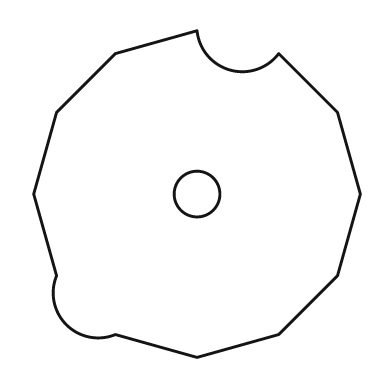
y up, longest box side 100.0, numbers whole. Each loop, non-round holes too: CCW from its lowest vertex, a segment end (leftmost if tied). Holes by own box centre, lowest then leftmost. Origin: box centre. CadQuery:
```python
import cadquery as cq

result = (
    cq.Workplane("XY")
    .moveTo(0.0, -50.0)
    .lineTo(25.0, -43.0)
    .lineTo(43.0, -25.0)
    .lineTo(50.0, 0.0)
    .lineTo(43.0, 25.0)
    .lineTo(25.0, 43.0)
    .threePointArc((10.0, 38.0), (0.0, 50.0))
    .lineTo(-25.0, 43.0)
    .lineTo(-43.0, 25.0)
    .lineTo(-50.0, 0.0)
    .lineTo(-43.0, -25.0)
    .threePointArc((-40.0, -40.0), (-25.0, -43.0))
    .close()
    .moveTo(0.0, 0.0)
    .circle(7.0)
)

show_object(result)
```